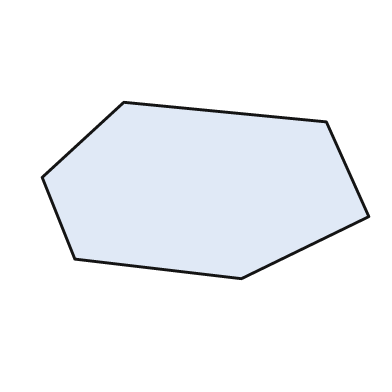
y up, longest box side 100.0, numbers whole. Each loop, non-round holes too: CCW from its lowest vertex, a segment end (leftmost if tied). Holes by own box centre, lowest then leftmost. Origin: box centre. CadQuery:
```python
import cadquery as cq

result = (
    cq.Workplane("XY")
    .moveTo(11.0, -27.0)
    .lineTo(50.0, -8.0)
    .lineTo(37.0, 21.0)
    .lineTo(-25.0, 27.0)
    .lineTo(-50.0, 4.0)
    .lineTo(-40.0, -21.0)
    .close()
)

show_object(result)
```